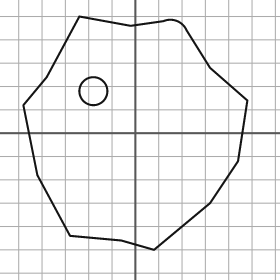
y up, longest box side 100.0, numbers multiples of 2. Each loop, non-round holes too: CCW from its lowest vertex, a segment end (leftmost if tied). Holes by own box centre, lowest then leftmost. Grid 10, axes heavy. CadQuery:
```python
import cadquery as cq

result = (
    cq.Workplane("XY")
    .moveTo(8.0, -50.0)
    .lineTo(32.0, -30.0)
    .lineTo(44.0, -12.0)
    .lineTo(48.0, 14.0)
    .lineTo(32.0, 28.0)
    .lineTo(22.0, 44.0)
    .threePointArc((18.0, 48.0), (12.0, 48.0))
    .lineTo(-2.0, 46.0)
    .lineTo(-24.0, 50.0)
    .lineTo(-38.0, 24.0)
    .lineTo(-48.0, 12.0)
    .lineTo(-42.0, -18.0)
    .lineTo(-28.0, -44.0)
    .lineTo(-6.0, -46.0)
    .close()
    .moveTo(-18.0, 18.0)
    .circle(6.0)
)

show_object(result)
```